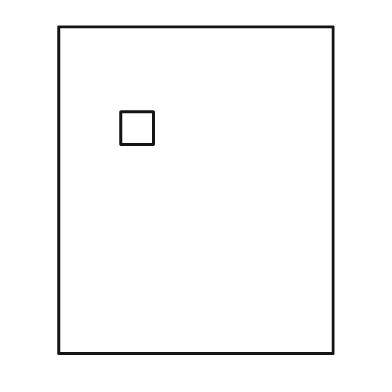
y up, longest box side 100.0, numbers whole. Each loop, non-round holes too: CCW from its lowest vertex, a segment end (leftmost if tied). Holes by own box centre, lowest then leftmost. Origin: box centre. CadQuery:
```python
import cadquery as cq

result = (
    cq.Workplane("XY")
    .moveTo(-42.0, -50.0)
    .lineTo(42.0, -50.0)
    .lineTo(42.0, 50.0)
    .lineTo(-42.0, 50.0)
    .close()
    .moveTo(-23.0, 14.0)
    .lineTo(-13.0, 14.0)
    .lineTo(-13.0, 24.0)
    .lineTo(-23.0, 24.0)
    .close()
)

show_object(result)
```